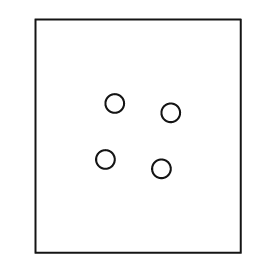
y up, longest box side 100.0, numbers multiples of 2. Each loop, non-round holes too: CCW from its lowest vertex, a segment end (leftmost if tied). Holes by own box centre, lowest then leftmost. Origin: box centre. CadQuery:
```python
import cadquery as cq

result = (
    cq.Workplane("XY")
    .moveTo(-44.0, -50.0)
    .lineTo(44.0, -50.0)
    .lineTo(44.0, 50.0)
    .lineTo(-44.0, 50.0)
    .close()
    .moveTo(10.0, -14.0)
    .circle(4.0)
    .moveTo(-14.0, -10.0)
    .circle(4.0)
    .moveTo(14.0, 10.0)
    .circle(4.0)
    .moveTo(-10.0, 14.0)
    .circle(4.0)
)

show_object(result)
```